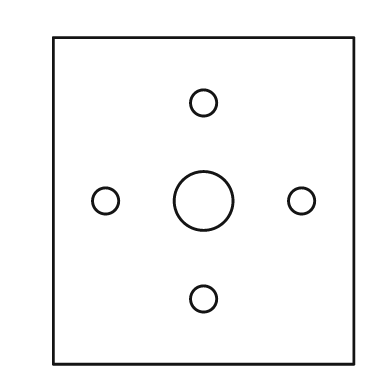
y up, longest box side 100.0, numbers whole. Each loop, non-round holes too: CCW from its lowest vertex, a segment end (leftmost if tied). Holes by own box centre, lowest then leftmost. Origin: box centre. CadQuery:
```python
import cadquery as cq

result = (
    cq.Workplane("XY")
    .moveTo(-46.0, -50.0)
    .lineTo(46.0, -50.0)
    .lineTo(46.0, 50.0)
    .lineTo(-46.0, 50.0)
    .close()
    .moveTo(0.0, -30.0)
    .circle(4.0)
    .moveTo(-30.0, 0.0)
    .circle(4.0)
    .moveTo(0.0, 0.0)
    .circle(9.0)
    .moveTo(30.0, 0.0)
    .circle(4.0)
    .moveTo(0.0, 30.0)
    .circle(4.0)
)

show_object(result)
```